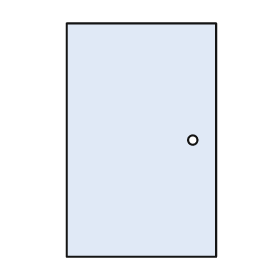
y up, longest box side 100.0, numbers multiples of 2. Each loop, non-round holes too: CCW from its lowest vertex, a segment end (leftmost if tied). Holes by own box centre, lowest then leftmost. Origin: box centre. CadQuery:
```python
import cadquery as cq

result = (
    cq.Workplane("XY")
    .moveTo(-32.0, -50.0)
    .lineTo(32.0, -50.0)
    .lineTo(32.0, 50.0)
    .lineTo(-32.0, 50.0)
    .close()
    .moveTo(22.0, 0.0)
    .circle(2.0)
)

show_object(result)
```